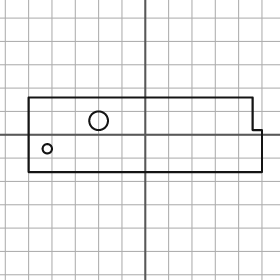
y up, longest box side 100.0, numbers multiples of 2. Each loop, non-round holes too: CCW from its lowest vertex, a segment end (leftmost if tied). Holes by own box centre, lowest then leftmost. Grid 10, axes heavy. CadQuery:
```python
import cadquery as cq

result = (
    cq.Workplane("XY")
    .moveTo(-50.0, -16.0)
    .lineTo(50.0, -16.0)
    .lineTo(50.0, 2.0)
    .lineTo(46.0, 2.0)
    .lineTo(46.0, 16.0)
    .lineTo(-50.0, 16.0)
    .close()
    .moveTo(-42.0, -6.0)
    .circle(2.0)
    .moveTo(-20.0, 6.0)
    .circle(4.0)
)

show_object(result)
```